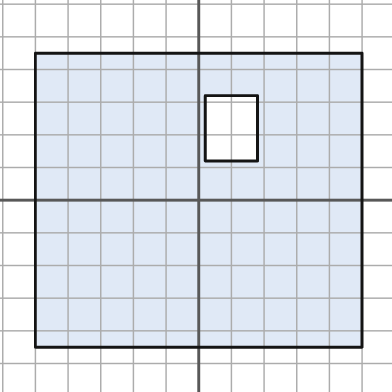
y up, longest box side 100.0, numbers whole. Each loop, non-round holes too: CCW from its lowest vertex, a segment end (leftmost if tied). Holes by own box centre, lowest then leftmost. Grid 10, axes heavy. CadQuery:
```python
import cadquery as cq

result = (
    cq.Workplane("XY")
    .moveTo(-50.0, -45.0)
    .lineTo(50.0, -45.0)
    .lineTo(50.0, 45.0)
    .lineTo(-50.0, 45.0)
    .close()
    .moveTo(2.0, 12.0)
    .lineTo(18.0, 12.0)
    .lineTo(18.0, 32.0)
    .lineTo(2.0, 32.0)
    .close()
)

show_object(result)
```